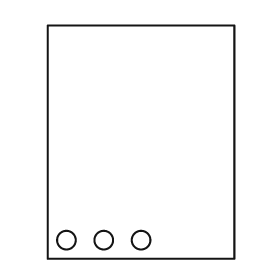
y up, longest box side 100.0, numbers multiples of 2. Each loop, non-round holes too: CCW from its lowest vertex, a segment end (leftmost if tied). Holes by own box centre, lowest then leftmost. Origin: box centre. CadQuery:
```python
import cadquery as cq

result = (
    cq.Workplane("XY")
    .moveTo(-40.0, -50.0)
    .lineTo(40.0, -50.0)
    .lineTo(40.0, 50.0)
    .lineTo(-40.0, 50.0)
    .close()
    .moveTo(-32.0, -42.0)
    .circle(4.0)
    .moveTo(-16.0, -42.0)
    .circle(4.0)
    .moveTo(0.0, -42.0)
    .circle(4.0)
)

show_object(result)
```